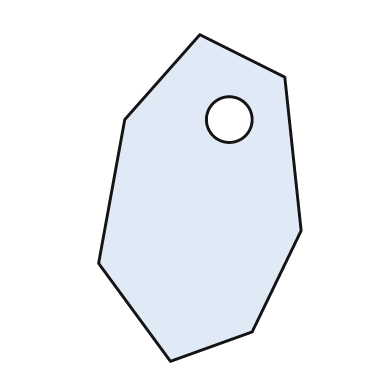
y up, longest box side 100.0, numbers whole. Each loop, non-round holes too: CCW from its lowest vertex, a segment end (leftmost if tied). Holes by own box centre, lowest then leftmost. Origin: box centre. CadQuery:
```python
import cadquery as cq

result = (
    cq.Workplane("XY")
    .moveTo(-9.0, -50.0)
    .lineTo(16.0, -41.0)
    .lineTo(31.0, -10.0)
    .lineTo(26.0, 37.0)
    .lineTo(0.0, 50.0)
    .lineTo(-23.0, 24.0)
    .lineTo(-31.0, -20.0)
    .close()
    .moveTo(9.0, 24.0)
    .circle(7.0)
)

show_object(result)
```